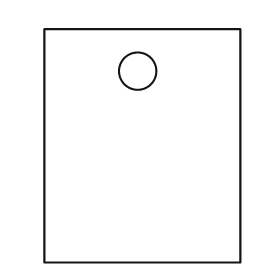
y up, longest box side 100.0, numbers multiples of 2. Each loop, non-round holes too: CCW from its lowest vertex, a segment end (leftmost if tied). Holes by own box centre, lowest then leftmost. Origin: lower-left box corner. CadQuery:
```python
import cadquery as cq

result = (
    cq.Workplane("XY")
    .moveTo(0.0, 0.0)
    .lineTo(84.0, 0.0)
    .lineTo(84.0, 100.0)
    .lineTo(0.0, 100.0)
    .close()
    .moveTo(40.0, 82.0)
    .circle(8.0)
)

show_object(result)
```